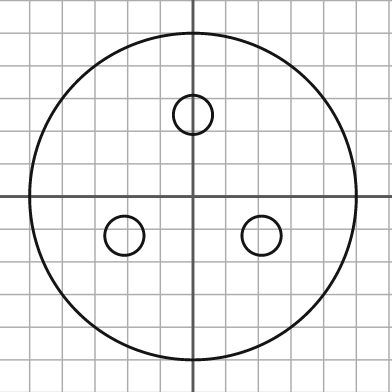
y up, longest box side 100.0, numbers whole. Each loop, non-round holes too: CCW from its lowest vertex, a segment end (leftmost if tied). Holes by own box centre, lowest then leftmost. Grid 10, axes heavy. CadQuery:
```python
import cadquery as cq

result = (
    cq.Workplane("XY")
    .moveTo(0.0, 0.0)
    .circle(50.0)
    .moveTo(-21.0, -12.0)
    .circle(6.0)
    .moveTo(21.0, -12.0)
    .circle(6.0)
    .moveTo(0.0, 25.0)
    .circle(6.0)
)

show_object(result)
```